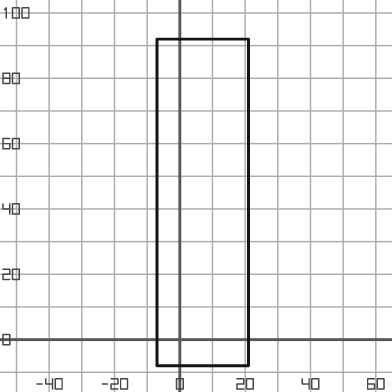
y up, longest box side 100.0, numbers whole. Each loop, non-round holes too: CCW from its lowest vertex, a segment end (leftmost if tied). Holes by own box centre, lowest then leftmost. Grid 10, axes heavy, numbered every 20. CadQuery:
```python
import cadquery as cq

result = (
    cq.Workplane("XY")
    .moveTo(-7.0, -8.0)
    .lineTo(21.0, -8.0)
    .lineTo(21.0, 92.0)
    .lineTo(-7.0, 92.0)
    .close()
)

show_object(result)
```